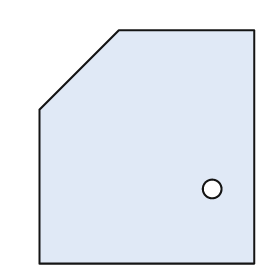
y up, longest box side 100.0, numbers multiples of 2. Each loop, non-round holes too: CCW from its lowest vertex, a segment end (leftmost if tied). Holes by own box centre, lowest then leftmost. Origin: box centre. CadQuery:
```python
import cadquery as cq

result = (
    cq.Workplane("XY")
    .moveTo(-46.0, -50.0)
    .lineTo(46.0, -50.0)
    .lineTo(46.0, 50.0)
    .lineTo(-12.0, 50.0)
    .lineTo(-46.0, 16.0)
    .close()
    .moveTo(28.0, -18.0)
    .circle(4.0)
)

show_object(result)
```